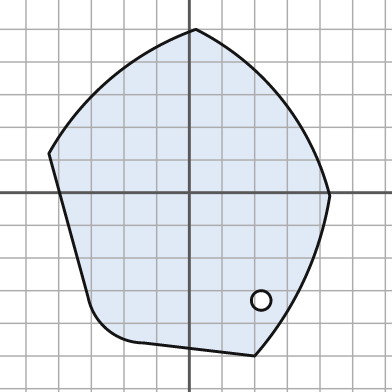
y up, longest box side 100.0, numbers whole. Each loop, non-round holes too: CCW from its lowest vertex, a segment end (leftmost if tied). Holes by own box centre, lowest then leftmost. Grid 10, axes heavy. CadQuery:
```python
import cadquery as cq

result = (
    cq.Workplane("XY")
    .moveTo(20.0, -50.0)
    .threePointArc((35.0, -27.0), (43.0, -1.0))
    .threePointArc((28.0, 29.0), (2.0, 50.0))
    .threePointArc((-24.0, 35.0), (-43.0, 12.0))
    .lineTo(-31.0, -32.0)
    .threePointArc((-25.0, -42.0), (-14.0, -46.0))
    .close()
    .moveTo(22.0, -33.0)
    .circle(3.0)
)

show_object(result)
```